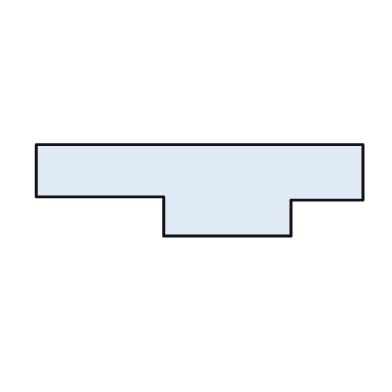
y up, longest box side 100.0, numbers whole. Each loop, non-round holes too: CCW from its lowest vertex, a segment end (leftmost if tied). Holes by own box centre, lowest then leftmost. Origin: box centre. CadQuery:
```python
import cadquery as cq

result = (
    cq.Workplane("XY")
    .moveTo(-11.0, -14.0)
    .lineTo(28.0, -14.0)
    .lineTo(28.0, -3.0)
    .lineTo(50.0, -3.0)
    .lineTo(50.0, 14.0)
    .lineTo(-50.0, 14.0)
    .lineTo(-50.0, -2.0)
    .lineTo(-11.0, -2.0)
    .close()
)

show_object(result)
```